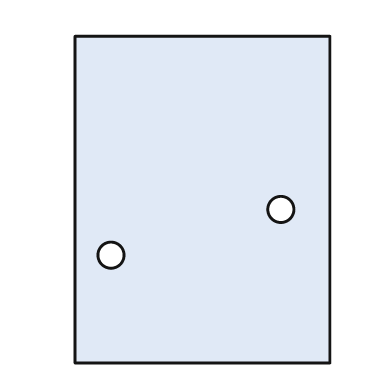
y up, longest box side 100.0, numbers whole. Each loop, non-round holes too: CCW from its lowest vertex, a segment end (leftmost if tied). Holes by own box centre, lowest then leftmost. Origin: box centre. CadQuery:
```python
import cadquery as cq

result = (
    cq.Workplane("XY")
    .moveTo(-39.0, -50.0)
    .lineTo(39.0, -50.0)
    .lineTo(39.0, 50.0)
    .lineTo(-39.0, 50.0)
    .close()
    .moveTo(-28.0, -17.0)
    .circle(4.0)
    .moveTo(24.0, -3.0)
    .circle(4.0)
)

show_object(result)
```